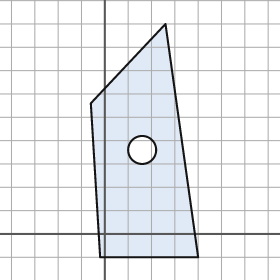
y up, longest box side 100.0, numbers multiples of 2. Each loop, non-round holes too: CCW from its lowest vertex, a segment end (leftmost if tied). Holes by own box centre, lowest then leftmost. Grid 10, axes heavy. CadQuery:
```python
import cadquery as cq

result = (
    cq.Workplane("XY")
    .moveTo(-2.0, -10.0)
    .lineTo(40.0, -10.0)
    .lineTo(26.0, 90.0)
    .lineTo(-6.0, 56.0)
    .close()
    .moveTo(16.0, 36.0)
    .circle(6.0)
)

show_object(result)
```